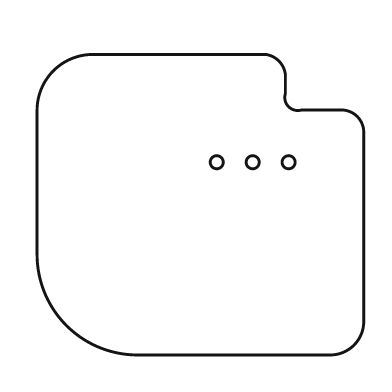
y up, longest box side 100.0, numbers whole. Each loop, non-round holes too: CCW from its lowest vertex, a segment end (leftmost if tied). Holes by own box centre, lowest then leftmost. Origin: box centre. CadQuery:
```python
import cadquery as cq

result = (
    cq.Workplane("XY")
    .moveTo(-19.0, -46.0)
    .lineTo(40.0, -46.0)
    .threePointArc((47.0, -43.0), (50.0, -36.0))
    .lineTo(50.0, 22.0)
    .threePointArc((48.0, 27.0), (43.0, 29.0))
    .lineTo(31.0, 29.0)
    .threePointArc((27.0, 30.0), (26.0, 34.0))
    .lineTo(26.0, 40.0)
    .threePointArc((24.0, 44.0), (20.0, 46.0))
    .lineTo(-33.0, 46.0)
    .threePointArc((-45.0, 41.0), (-50.0, 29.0))
    .lineTo(-50.0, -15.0)
    .threePointArc((-41.0, -37.0), (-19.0, -46.0))
    .close()
    .moveTo(5.0, 13.0)
    .circle(2.0)
    .moveTo(16.0, 13.0)
    .circle(2.0)
    .moveTo(27.0, 13.0)
    .circle(2.0)
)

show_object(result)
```